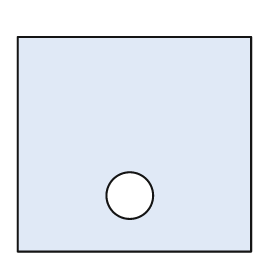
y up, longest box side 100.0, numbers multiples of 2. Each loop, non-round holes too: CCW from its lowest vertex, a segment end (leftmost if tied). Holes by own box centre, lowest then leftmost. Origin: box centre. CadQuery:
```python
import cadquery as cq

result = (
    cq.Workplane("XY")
    .moveTo(-50.0, -46.0)
    .lineTo(50.0, -46.0)
    .lineTo(50.0, 46.0)
    .lineTo(-50.0, 46.0)
    .close()
    .moveTo(-2.0, -22.0)
    .circle(10.0)
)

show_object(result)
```